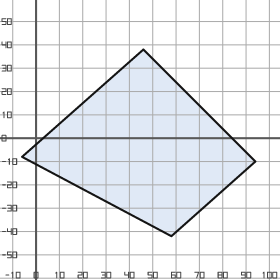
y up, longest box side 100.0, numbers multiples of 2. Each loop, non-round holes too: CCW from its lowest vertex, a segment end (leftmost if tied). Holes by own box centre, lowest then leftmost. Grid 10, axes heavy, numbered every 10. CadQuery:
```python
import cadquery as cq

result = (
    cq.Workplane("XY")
    .moveTo(58.0, -42.0)
    .lineTo(94.0, -10.0)
    .lineTo(46.0, 38.0)
    .lineTo(-6.0, -8.0)
    .close()
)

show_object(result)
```